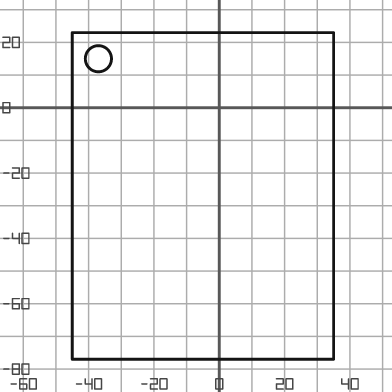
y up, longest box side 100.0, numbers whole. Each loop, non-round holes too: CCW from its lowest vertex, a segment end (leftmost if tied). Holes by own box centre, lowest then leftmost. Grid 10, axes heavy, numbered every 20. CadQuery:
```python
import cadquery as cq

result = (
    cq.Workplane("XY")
    .moveTo(-45.0, -77.0)
    .lineTo(35.0, -77.0)
    .lineTo(35.0, 23.0)
    .lineTo(-45.0, 23.0)
    .close()
    .moveTo(-37.0, 15.0)
    .circle(4.0)
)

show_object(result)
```